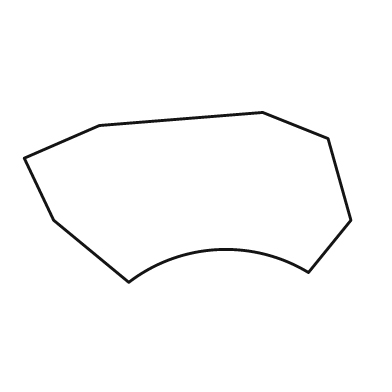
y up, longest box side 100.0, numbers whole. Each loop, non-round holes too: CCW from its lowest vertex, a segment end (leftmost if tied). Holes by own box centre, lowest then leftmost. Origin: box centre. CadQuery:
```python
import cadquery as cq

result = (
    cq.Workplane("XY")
    .moveTo(-18.0, -26.0)
    .threePointArc((9.0, -16.0), (37.0, -23.0))
    .lineTo(50.0, -7.0)
    .lineTo(43.0, 18.0)
    .lineTo(23.0, 26.0)
    .lineTo(-27.0, 22.0)
    .lineTo(-50.0, 12.0)
    .lineTo(-41.0, -7.0)
    .close()
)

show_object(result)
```